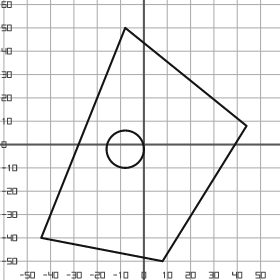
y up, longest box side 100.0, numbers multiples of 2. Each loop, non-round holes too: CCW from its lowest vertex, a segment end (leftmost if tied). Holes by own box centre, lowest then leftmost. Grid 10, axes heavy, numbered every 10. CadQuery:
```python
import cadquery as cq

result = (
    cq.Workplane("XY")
    .moveTo(8.0, -50.0)
    .lineTo(44.0, 8.0)
    .lineTo(-8.0, 50.0)
    .lineTo(-44.0, -40.0)
    .close()
    .moveTo(-8.0, -2.0)
    .circle(8.0)
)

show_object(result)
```